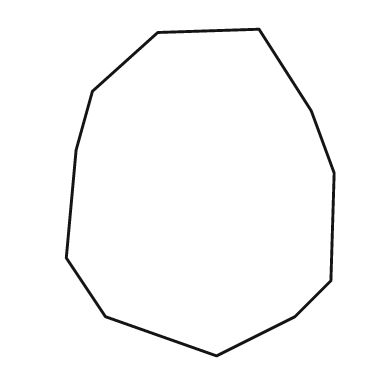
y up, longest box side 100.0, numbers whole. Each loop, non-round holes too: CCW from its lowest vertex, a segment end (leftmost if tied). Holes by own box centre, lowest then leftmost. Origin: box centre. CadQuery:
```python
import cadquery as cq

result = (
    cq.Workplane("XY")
    .moveTo(5.0, -50.0)
    .lineTo(29.0, -38.0)
    .lineTo(40.0, -27.0)
    .lineTo(41.0, 6.0)
    .lineTo(34.0, 25.0)
    .lineTo(18.0, 50.0)
    .lineTo(-13.0, 49.0)
    .lineTo(-33.0, 31.0)
    .lineTo(-38.0, 13.0)
    .lineTo(-41.0, -20.0)
    .lineTo(-29.0, -38.0)
    .close()
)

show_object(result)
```